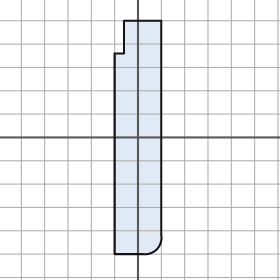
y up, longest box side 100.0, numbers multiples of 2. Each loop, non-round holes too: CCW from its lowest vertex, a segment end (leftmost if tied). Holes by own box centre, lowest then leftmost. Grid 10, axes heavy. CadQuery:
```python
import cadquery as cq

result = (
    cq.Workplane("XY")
    .moveTo(-10.0, -50.0)
    .lineTo(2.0, -50.0)
    .threePointArc((8.0, -48.0), (10.0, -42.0))
    .lineTo(10.0, 50.0)
    .lineTo(-6.0, 50.0)
    .lineTo(-6.0, 36.0)
    .lineTo(-10.0, 36.0)
    .close()
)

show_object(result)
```